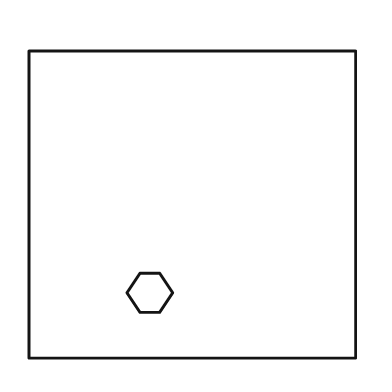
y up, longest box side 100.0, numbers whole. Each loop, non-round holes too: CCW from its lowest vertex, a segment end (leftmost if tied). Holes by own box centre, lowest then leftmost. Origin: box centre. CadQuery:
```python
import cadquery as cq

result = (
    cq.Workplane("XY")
    .moveTo(-50.0, -47.0)
    .lineTo(50.0, -47.0)
    .lineTo(50.0, 47.0)
    .lineTo(-50.0, 47.0)
    .close()
    .moveTo(-16.0, -33.0)
    .lineTo(-10.0, -33.0)
    .lineTo(-6.0, -27.0)
    .lineTo(-10.0, -21.0)
    .lineTo(-16.0, -21.0)
    .lineTo(-20.0, -27.0)
    .close()
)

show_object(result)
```